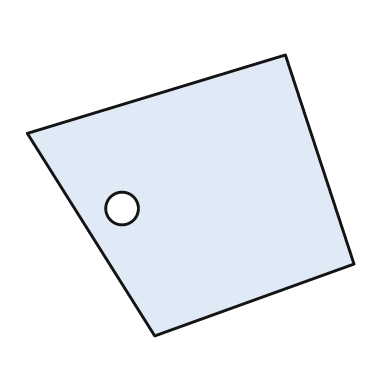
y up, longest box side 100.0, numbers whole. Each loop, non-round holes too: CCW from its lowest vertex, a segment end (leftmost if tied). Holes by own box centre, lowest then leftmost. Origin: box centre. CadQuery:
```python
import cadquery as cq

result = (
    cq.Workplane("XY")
    .moveTo(-11.0, -43.0)
    .lineTo(50.0, -21.0)
    .lineTo(29.0, 43.0)
    .lineTo(-50.0, 19.0)
    .close()
    .moveTo(-21.0, -4.0)
    .circle(5.0)
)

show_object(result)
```